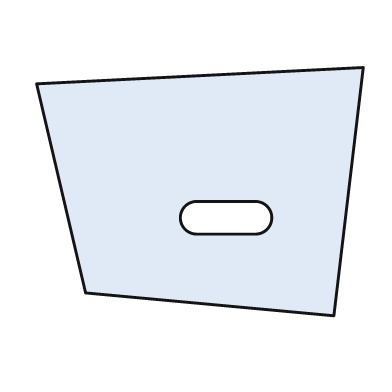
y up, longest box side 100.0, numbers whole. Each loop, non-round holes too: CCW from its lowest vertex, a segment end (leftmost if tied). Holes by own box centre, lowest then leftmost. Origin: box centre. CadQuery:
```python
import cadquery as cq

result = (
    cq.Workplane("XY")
    .moveTo(41.0, -38.0)
    .lineTo(50.0, 38.0)
    .lineTo(-50.0, 33.0)
    .lineTo(-35.0, -31.0)
    .close()
    .moveTo(-1.0, -13.0)
    .lineTo(17.0, -13.0)
    .threePointArc((22.0, -8.0), (17.0, -3.0))
    .lineTo(-1.0, -3.0)
    .threePointArc((-6.0, -8.0), (-1.0, -13.0))
    .close()
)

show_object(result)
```